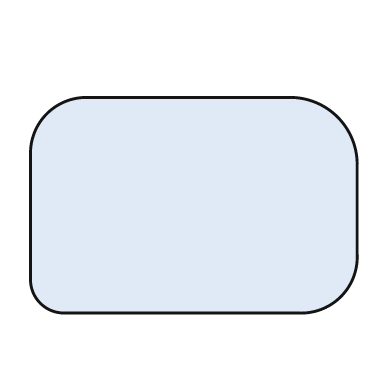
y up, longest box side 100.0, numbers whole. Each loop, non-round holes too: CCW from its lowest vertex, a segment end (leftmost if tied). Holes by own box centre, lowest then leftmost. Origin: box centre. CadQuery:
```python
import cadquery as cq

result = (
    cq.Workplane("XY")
    .moveTo(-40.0, -33.0)
    .lineTo(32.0, -33.0)
    .threePointArc((45.0, -28.0), (50.0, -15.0))
    .lineTo(50.0, 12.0)
    .threePointArc((44.0, 27.0), (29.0, 33.0))
    .lineTo(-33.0, 33.0)
    .threePointArc((-45.0, 28.0), (-50.0, 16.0))
    .lineTo(-50.0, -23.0)
    .threePointArc((-47.0, -30.0), (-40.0, -33.0))
    .close()
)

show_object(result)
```